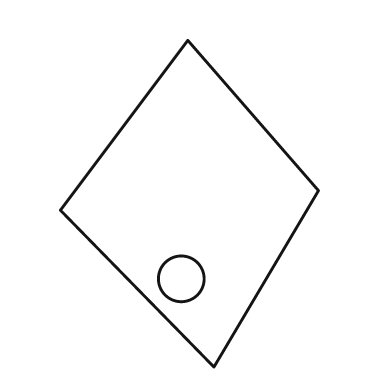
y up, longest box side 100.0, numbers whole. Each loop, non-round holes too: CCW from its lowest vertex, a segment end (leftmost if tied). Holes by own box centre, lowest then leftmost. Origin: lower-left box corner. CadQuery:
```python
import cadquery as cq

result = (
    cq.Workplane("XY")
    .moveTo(47.0, 0.0)
    .lineTo(79.0, 54.0)
    .lineTo(39.0, 100.0)
    .lineTo(0.0, 48.0)
    .close()
    .moveTo(37.0, 27.0)
    .circle(7.0)
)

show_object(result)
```